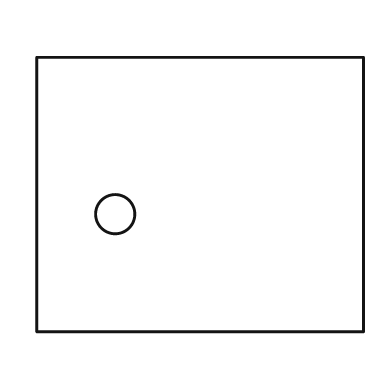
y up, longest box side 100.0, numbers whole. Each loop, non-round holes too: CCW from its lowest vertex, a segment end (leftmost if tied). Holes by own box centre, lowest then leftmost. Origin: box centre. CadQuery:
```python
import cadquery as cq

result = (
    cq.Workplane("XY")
    .moveTo(-50.0, -42.0)
    .lineTo(50.0, -42.0)
    .lineTo(50.0, 42.0)
    .lineTo(-50.0, 42.0)
    .close()
    .moveTo(-26.0, -6.0)
    .circle(6.0)
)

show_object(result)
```